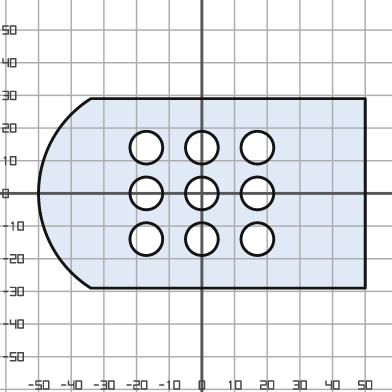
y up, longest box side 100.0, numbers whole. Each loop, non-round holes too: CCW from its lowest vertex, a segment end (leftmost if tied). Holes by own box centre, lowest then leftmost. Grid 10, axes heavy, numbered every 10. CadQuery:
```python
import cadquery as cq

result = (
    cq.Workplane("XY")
    .moveTo(-34.0, -29.0)
    .lineTo(50.0, -29.0)
    .lineTo(50.0, 29.0)
    .lineTo(-34.0, 29.0)
    .threePointArc((-50.0, 0.0), (-34.0, -29.0))
    .close()
    .moveTo(-17.0, -14.0)
    .circle(5.0)
    .moveTo(0.0, -14.0)
    .circle(5.0)
    .moveTo(17.0, -14.0)
    .circle(5.0)
    .moveTo(-17.0, 0.0)
    .circle(5.0)
    .moveTo(0.0, 0.0)
    .circle(5.0)
    .moveTo(17.0, 0.0)
    .circle(5.0)
    .moveTo(-17.0, 14.0)
    .circle(5.0)
    .moveTo(0.0, 14.0)
    .circle(5.0)
    .moveTo(17.0, 14.0)
    .circle(5.0)
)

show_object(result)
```